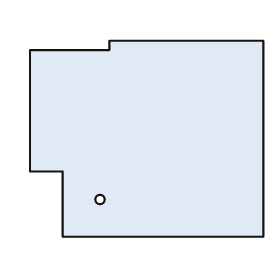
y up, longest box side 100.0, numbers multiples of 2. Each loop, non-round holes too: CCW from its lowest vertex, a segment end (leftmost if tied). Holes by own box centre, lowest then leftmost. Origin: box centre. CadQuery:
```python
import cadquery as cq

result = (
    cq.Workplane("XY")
    .moveTo(-36.0, -42.0)
    .lineTo(50.0, -42.0)
    .lineTo(50.0, 42.0)
    .lineTo(-16.0, 42.0)
    .lineTo(-16.0, 38.0)
    .lineTo(-50.0, 38.0)
    .lineTo(-50.0, -14.0)
    .lineTo(-36.0, -14.0)
    .close()
    .moveTo(-20.0, -26.0)
    .circle(2.0)
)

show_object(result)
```